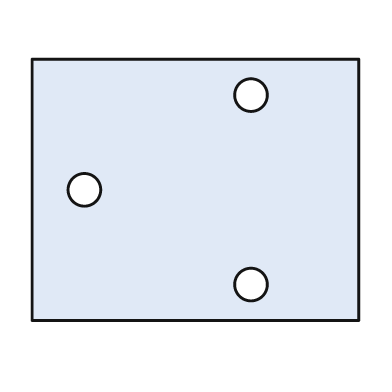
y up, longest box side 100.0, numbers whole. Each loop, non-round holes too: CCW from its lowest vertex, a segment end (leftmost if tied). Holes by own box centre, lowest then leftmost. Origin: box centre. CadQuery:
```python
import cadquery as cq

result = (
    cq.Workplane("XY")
    .moveTo(-50.0, -40.0)
    .lineTo(50.0, -40.0)
    .lineTo(50.0, 40.0)
    .lineTo(-50.0, 40.0)
    .close()
    .moveTo(17.0, -29.0)
    .circle(5.0)
    .moveTo(-34.0, 0.0)
    .circle(5.0)
    .moveTo(17.0, 29.0)
    .circle(5.0)
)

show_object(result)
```